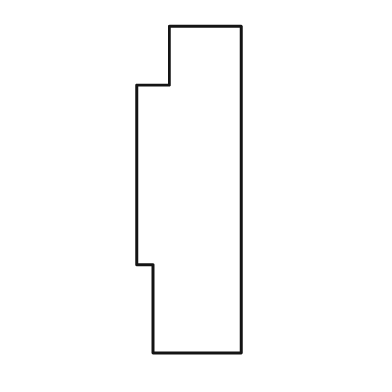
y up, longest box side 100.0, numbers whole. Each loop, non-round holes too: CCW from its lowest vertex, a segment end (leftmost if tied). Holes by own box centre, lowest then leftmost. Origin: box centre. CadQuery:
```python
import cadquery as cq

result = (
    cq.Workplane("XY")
    .moveTo(-11.0, -50.0)
    .lineTo(16.0, -50.0)
    .lineTo(16.0, 50.0)
    .lineTo(-6.0, 50.0)
    .lineTo(-6.0, 32.0)
    .lineTo(-16.0, 32.0)
    .lineTo(-16.0, -23.0)
    .lineTo(-11.0, -23.0)
    .close()
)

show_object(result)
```